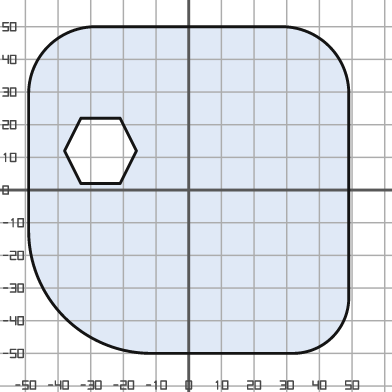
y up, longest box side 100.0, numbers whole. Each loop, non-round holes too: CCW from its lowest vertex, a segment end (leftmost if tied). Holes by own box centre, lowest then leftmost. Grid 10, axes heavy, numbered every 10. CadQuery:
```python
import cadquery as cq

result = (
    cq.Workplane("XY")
    .moveTo(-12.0, -50.0)
    .lineTo(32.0, -50.0)
    .threePointArc((44.0, -45.0), (49.0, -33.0))
    .lineTo(49.0, 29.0)
    .threePointArc((43.0, 44.0), (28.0, 50.0))
    .lineTo(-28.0, 50.0)
    .threePointArc((-43.0, 44.0), (-49.0, 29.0))
    .lineTo(-49.0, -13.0)
    .threePointArc((-38.0, -39.0), (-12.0, -50.0))
    .close()
    .moveTo(-33.0, 2.0)
    .lineTo(-21.0, 2.0)
    .lineTo(-16.0, 12.0)
    .lineTo(-21.0, 22.0)
    .lineTo(-33.0, 22.0)
    .lineTo(-38.0, 12.0)
    .close()
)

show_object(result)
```